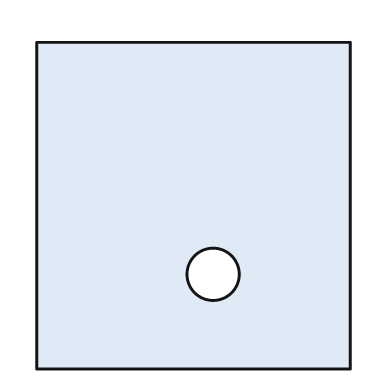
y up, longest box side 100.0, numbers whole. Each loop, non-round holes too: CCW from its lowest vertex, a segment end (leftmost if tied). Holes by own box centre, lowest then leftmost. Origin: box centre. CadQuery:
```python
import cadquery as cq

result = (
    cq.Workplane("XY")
    .moveTo(-48.0, -50.0)
    .lineTo(48.0, -50.0)
    .lineTo(48.0, 50.0)
    .lineTo(-48.0, 50.0)
    .close()
    .moveTo(6.0, -21.0)
    .circle(8.0)
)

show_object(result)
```